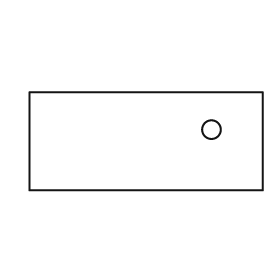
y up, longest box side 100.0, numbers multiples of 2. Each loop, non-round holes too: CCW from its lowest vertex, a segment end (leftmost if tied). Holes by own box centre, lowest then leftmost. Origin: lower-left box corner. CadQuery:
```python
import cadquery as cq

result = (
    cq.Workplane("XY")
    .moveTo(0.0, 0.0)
    .lineTo(100.0, 0.0)
    .lineTo(100.0, 42.0)
    .lineTo(0.0, 42.0)
    .close()
    .moveTo(78.0, 26.0)
    .circle(4.0)
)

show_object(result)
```